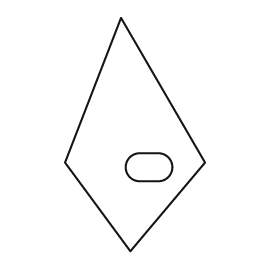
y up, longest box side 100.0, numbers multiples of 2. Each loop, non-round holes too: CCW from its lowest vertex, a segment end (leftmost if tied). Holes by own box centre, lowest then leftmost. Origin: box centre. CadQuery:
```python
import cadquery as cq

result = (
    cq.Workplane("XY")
    .moveTo(-2.0, -50.0)
    .lineTo(30.0, -12.0)
    .lineTo(-6.0, 50.0)
    .lineTo(-30.0, -12.0)
    .close()
    .moveTo(2.0, -20.0)
    .lineTo(10.0, -20.0)
    .threePointArc((16.0, -14.0), (10.0, -8.0))
    .lineTo(2.0, -8.0)
    .threePointArc((-4.0, -14.0), (2.0, -20.0))
    .close()
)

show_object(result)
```